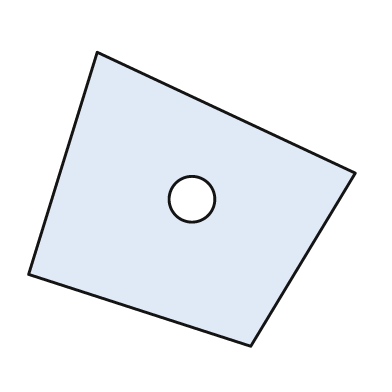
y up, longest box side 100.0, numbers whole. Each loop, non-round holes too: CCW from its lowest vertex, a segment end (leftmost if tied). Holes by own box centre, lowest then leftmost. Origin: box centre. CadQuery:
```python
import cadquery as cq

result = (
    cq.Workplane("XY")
    .moveTo(18.0, -45.0)
    .lineTo(50.0, 8.0)
    .lineTo(-29.0, 45.0)
    .lineTo(-50.0, -23.0)
    .close()
    .moveTo(0.0, 0.0)
    .circle(7.0)
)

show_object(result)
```